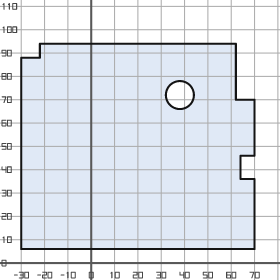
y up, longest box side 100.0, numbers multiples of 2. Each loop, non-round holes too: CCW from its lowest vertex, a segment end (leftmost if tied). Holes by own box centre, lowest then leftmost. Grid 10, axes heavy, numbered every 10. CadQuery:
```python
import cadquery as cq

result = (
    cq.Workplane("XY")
    .moveTo(-30.0, 6.0)
    .lineTo(70.0, 6.0)
    .lineTo(70.0, 36.0)
    .lineTo(64.0, 36.0)
    .lineTo(64.0, 46.0)
    .lineTo(70.0, 46.0)
    .lineTo(70.0, 70.0)
    .lineTo(62.0, 70.0)
    .lineTo(62.0, 94.0)
    .lineTo(-22.0, 94.0)
    .lineTo(-22.0, 88.0)
    .lineTo(-30.0, 88.0)
    .close()
    .moveTo(38.0, 72.0)
    .circle(6.0)
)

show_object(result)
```